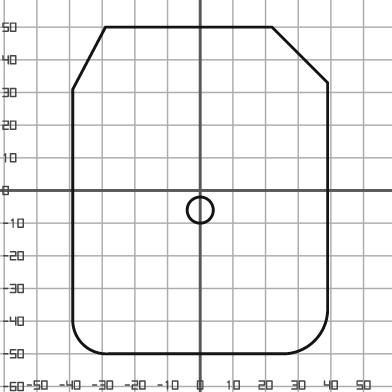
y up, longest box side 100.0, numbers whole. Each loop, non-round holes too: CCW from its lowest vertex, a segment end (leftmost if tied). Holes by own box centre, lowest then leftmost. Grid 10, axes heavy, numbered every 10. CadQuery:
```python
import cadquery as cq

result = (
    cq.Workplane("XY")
    .moveTo(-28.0, -50.0)
    .lineTo(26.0, -50.0)
    .threePointArc((35.0, -46.0), (39.0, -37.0))
    .lineTo(39.0, 33.0)
    .lineTo(22.0, 50.0)
    .lineTo(-29.0, 50.0)
    .lineTo(-39.0, 31.0)
    .lineTo(-39.0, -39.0)
    .threePointArc((-36.0, -47.0), (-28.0, -50.0))
    .close()
    .moveTo(0.0, -6.0)
    .circle(4.0)
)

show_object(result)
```